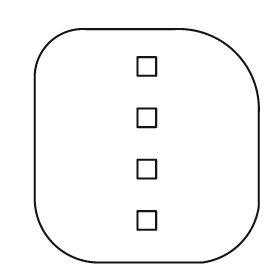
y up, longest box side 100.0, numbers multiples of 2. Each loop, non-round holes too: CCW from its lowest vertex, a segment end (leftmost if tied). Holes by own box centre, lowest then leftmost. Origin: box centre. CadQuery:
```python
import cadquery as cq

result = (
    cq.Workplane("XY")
    .moveTo(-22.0, -50.0)
    .lineTo(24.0, -50.0)
    .threePointArc((40.0, -42.0), (48.0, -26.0))
    .lineTo(48.0, 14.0)
    .threePointArc((38.0, 40.0), (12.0, 50.0))
    .lineTo(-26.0, 50.0)
    .threePointArc((-42.0, 44.0), (-48.0, 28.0))
    .lineTo(-48.0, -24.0)
    .threePointArc((-40.0, -42.0), (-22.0, -50.0))
    .close()
    .moveTo(-4.0, -36.0)
    .lineTo(4.0, -36.0)
    .lineTo(4.0, -28.0)
    .lineTo(-4.0, -28.0)
    .close()
    .moveTo(-4.0, -14.0)
    .lineTo(4.0, -14.0)
    .lineTo(4.0, -6.0)
    .lineTo(-4.0, -6.0)
    .close()
    .moveTo(-4.0, 8.0)
    .lineTo(4.0, 8.0)
    .lineTo(4.0, 16.0)
    .lineTo(-4.0, 16.0)
    .close()
    .moveTo(-4.0, 30.0)
    .lineTo(4.0, 30.0)
    .lineTo(4.0, 38.0)
    .lineTo(-4.0, 38.0)
    .close()
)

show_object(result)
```